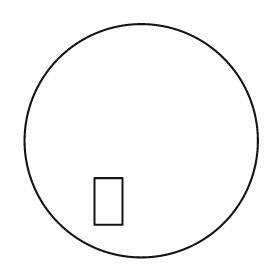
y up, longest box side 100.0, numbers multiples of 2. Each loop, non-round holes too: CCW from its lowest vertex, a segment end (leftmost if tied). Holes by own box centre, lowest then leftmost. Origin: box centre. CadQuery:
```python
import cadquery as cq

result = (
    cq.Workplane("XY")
    .moveTo(0.0, 0.0)
    .circle(50.0)
    .moveTo(-20.0, -36.0)
    .lineTo(-8.0, -36.0)
    .lineTo(-8.0, -16.0)
    .lineTo(-20.0, -16.0)
    .close()
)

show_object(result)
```